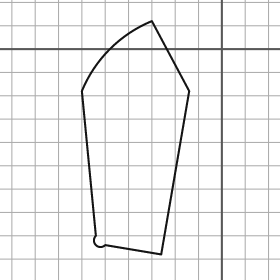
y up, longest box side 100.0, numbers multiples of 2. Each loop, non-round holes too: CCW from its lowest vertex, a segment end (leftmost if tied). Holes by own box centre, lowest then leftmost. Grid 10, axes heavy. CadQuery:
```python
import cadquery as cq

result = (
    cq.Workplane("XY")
    .moveTo(-26.0, -88.0)
    .lineTo(-14.0, -18.0)
    .lineTo(-30.0, 12.0)
    .threePointArc((-48.0, 0.0), (-60.0, -18.0))
    .lineTo(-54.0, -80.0)
    .threePointArc((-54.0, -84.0), (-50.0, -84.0))
    .close()
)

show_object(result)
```